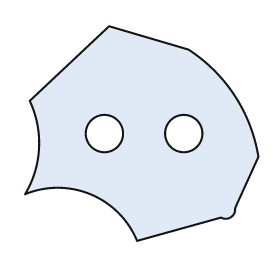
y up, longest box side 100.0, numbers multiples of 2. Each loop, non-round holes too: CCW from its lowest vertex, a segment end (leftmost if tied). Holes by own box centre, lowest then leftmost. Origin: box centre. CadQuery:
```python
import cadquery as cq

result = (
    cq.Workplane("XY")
    .moveTo(-2.0, -46.0)
    .lineTo(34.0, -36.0)
    .threePointArc((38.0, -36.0), (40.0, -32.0))
    .lineTo(50.0, -10.0)
    .threePointArc((40.0, 16.0), (20.0, 36.0))
    .lineTo(-14.0, 46.0)
    .lineTo(-48.0, 14.0)
    .threePointArc((-44.0, -6.0), (-50.0, -26.0))
    .threePointArc((-22.0, -26.0), (-2.0, -46.0))
    .close()
    .moveTo(-16.0, 0.0)
    .circle(8.0)
    .moveTo(18.0, 0.0)
    .circle(8.0)
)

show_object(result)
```